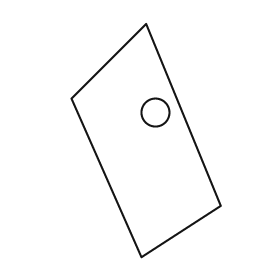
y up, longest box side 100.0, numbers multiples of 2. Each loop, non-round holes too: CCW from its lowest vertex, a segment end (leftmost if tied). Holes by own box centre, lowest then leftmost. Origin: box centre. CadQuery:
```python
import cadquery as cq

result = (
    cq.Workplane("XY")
    .moveTo(-2.0, -50.0)
    .lineTo(32.0, -28.0)
    .lineTo(0.0, 50.0)
    .lineTo(-32.0, 18.0)
    .close()
    .moveTo(4.0, 12.0)
    .circle(6.0)
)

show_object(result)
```